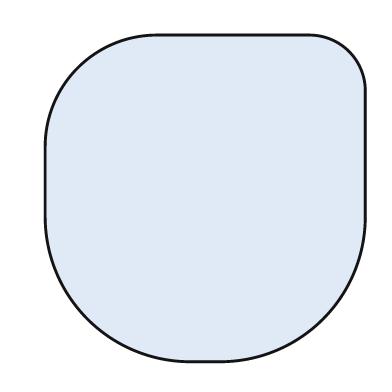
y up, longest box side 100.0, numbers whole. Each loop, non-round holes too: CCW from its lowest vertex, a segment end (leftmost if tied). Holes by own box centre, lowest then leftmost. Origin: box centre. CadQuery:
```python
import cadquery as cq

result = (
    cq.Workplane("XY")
    .moveTo(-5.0, -50.0)
    .lineTo(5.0, -50.0)
    .threePointArc((36.0, -37.0), (49.0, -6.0))
    .lineTo(49.0, 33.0)
    .threePointArc((44.0, 45.0), (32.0, 50.0))
    .lineTo(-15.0, 50.0)
    .threePointArc((-39.0, 40.0), (-49.0, 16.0))
    .lineTo(-49.0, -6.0)
    .threePointArc((-36.0, -37.0), (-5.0, -50.0))
    .close()
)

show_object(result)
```